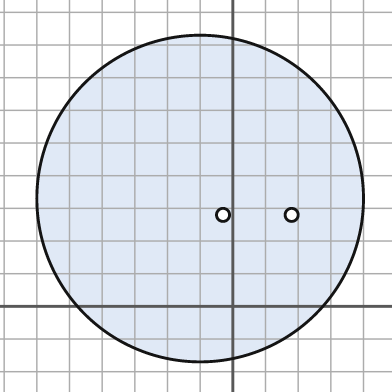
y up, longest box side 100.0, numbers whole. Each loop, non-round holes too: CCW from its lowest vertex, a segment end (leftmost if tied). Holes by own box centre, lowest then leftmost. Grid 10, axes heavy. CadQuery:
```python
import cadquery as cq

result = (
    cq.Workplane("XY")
    .moveTo(-10.0, 33.0)
    .circle(50.0)
    .moveTo(-3.0, 28.0)
    .circle(2.0)
    .moveTo(18.0, 28.0)
    .circle(2.0)
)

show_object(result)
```